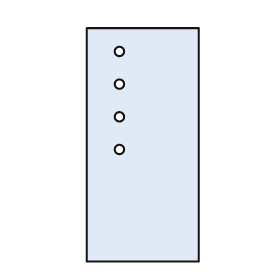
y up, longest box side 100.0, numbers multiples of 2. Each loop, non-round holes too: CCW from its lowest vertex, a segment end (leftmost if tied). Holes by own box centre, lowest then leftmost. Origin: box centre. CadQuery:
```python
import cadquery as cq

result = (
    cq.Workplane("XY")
    .moveTo(-24.0, -50.0)
    .lineTo(24.0, -50.0)
    .lineTo(24.0, 50.0)
    .lineTo(-24.0, 50.0)
    .close()
    .moveTo(-10.0, -2.0)
    .circle(2.0)
    .moveTo(-10.0, 12.0)
    .circle(2.0)
    .moveTo(-10.0, 26.0)
    .circle(2.0)
    .moveTo(-10.0, 40.0)
    .circle(2.0)
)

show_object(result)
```